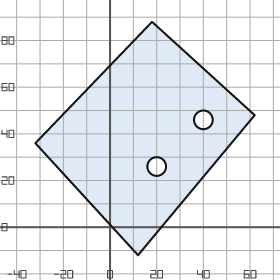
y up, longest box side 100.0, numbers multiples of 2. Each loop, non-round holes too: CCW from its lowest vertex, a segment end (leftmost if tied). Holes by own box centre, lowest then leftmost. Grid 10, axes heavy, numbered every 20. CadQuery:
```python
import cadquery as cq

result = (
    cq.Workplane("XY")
    .moveTo(12.0, -12.0)
    .lineTo(62.0, 48.0)
    .lineTo(18.0, 88.0)
    .lineTo(-32.0, 36.0)
    .close()
    .moveTo(20.0, 26.0)
    .circle(4.0)
    .moveTo(40.0, 46.0)
    .circle(4.0)
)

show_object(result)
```